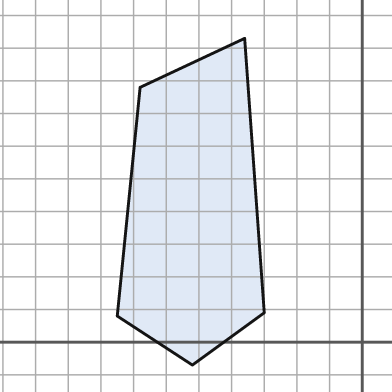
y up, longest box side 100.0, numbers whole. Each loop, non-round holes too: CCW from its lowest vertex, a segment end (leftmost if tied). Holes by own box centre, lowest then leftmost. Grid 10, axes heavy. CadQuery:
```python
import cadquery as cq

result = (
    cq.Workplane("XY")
    .moveTo(-52.0, -7.0)
    .lineTo(-30.0, 9.0)
    .lineTo(-36.0, 93.0)
    .lineTo(-68.0, 78.0)
    .lineTo(-75.0, 8.0)
    .close()
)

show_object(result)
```